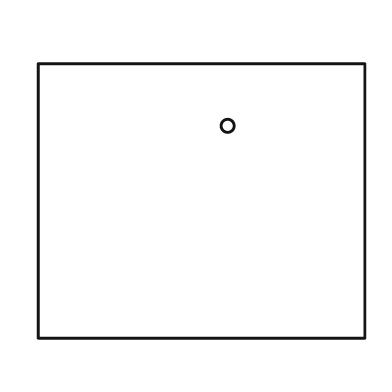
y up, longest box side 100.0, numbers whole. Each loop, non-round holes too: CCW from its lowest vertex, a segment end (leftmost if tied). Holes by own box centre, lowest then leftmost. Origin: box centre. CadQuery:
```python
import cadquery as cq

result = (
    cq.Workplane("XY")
    .moveTo(-50.0, -42.0)
    .lineTo(50.0, -42.0)
    .lineTo(50.0, 42.0)
    .lineTo(-50.0, 42.0)
    .close()
    .moveTo(8.0, 23.0)
    .circle(2.0)
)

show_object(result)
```